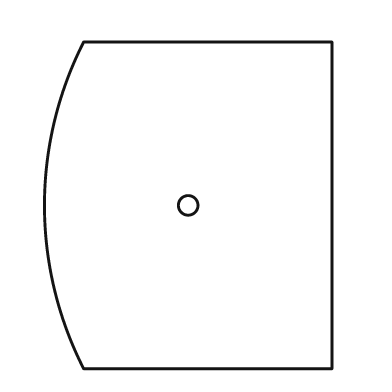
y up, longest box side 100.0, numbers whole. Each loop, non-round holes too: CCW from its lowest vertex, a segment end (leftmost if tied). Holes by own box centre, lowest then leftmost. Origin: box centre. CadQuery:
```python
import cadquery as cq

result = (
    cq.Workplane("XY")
    .moveTo(-32.0, -50.0)
    .lineTo(44.0, -50.0)
    .lineTo(44.0, 50.0)
    .lineTo(-32.0, 50.0)
    .threePointArc((-44.0, 0.0), (-32.0, -50.0))
    .close()
    .moveTo(0.0, 0.0)
    .circle(3.0)
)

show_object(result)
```